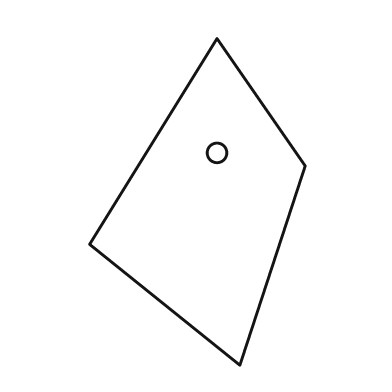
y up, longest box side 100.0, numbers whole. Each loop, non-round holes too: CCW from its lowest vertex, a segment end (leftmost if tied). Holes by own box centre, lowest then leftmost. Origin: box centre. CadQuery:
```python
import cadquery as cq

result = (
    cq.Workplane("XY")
    .moveTo(13.0, -50.0)
    .lineTo(33.0, 11.0)
    .lineTo(6.0, 50.0)
    .lineTo(-33.0, -13.0)
    .close()
    .moveTo(6.0, 15.0)
    .circle(3.0)
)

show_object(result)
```